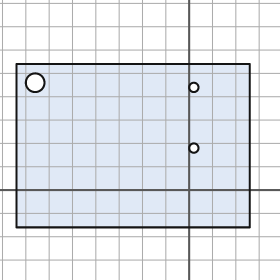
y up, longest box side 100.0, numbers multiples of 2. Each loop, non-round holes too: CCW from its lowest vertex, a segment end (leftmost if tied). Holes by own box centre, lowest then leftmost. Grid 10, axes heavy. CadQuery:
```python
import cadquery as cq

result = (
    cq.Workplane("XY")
    .moveTo(-74.0, -16.0)
    .lineTo(26.0, -16.0)
    .lineTo(26.0, 54.0)
    .lineTo(-74.0, 54.0)
    .close()
    .moveTo(2.0, 18.0)
    .circle(2.0)
    .moveTo(2.0, 44.0)
    .circle(2.0)
    .moveTo(-66.0, 46.0)
    .circle(4.0)
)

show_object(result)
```